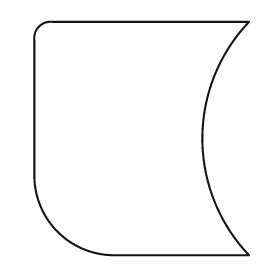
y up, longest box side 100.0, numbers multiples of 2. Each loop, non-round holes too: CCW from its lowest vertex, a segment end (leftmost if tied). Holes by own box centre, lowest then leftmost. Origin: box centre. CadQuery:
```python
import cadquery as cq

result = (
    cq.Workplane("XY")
    .moveTo(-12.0, -50.0)
    .lineTo(46.0, -50.0)
    .threePointArc((26.0, 0.0), (46.0, 50.0))
    .lineTo(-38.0, 50.0)
    .threePointArc((-44.0, 48.0), (-46.0, 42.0))
    .lineTo(-46.0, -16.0)
    .threePointArc((-36.0, -40.0), (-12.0, -50.0))
    .close()
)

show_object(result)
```